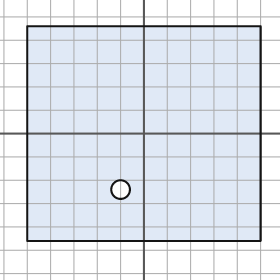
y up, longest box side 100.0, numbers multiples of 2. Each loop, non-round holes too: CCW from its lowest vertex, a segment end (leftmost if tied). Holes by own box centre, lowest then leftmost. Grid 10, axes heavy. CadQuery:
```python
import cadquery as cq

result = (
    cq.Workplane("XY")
    .moveTo(-50.0, -46.0)
    .lineTo(50.0, -46.0)
    .lineTo(50.0, 46.0)
    .lineTo(-50.0, 46.0)
    .close()
    .moveTo(-10.0, -24.0)
    .circle(4.0)
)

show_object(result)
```